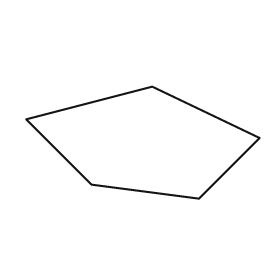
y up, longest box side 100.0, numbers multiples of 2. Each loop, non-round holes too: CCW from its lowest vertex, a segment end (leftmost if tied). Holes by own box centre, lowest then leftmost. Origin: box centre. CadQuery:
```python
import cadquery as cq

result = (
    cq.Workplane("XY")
    .moveTo(24.0, -24.0)
    .lineTo(50.0, 2.0)
    .lineTo(4.0, 24.0)
    .lineTo(-50.0, 10.0)
    .lineTo(-22.0, -18.0)
    .close()
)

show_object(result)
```